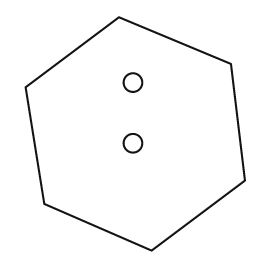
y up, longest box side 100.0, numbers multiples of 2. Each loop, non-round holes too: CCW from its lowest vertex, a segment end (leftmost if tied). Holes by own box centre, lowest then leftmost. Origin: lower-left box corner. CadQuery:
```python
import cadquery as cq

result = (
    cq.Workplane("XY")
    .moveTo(54.0, 0.0)
    .lineTo(94.0, 30.0)
    .lineTo(88.0, 80.0)
    .lineTo(40.0, 100.0)
    .lineTo(0.0, 70.0)
    .lineTo(8.0, 20.0)
    .close()
    .moveTo(46.0, 46.0)
    .circle(4.0)
    .moveTo(46.0, 72.0)
    .circle(4.0)
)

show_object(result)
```